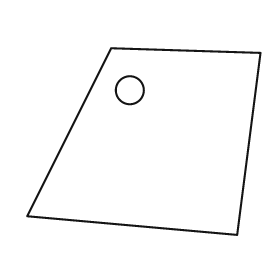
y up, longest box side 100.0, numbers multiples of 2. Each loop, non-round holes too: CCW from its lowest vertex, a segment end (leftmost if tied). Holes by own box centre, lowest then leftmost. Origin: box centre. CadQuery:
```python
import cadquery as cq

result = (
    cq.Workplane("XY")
    .moveTo(40.0, -40.0)
    .lineTo(50.0, 38.0)
    .lineTo(-14.0, 40.0)
    .lineTo(-50.0, -32.0)
    .close()
    .moveTo(-6.0, 22.0)
    .circle(6.0)
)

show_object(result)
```